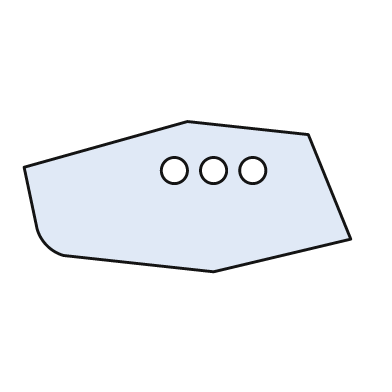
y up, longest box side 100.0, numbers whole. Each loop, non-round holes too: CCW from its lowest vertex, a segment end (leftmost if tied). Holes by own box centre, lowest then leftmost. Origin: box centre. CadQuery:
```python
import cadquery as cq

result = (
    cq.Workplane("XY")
    .moveTo(8.0, -23.0)
    .lineTo(50.0, -13.0)
    .lineTo(37.0, 19.0)
    .lineTo(0.0, 23.0)
    .lineTo(-50.0, 9.0)
    .lineTo(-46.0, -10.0)
    .threePointArc((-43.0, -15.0), (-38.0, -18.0))
    .close()
    .moveTo(-4.0, 8.0)
    .circle(4.0)
    .moveTo(8.0, 8.0)
    .circle(4.0)
    .moveTo(20.0, 8.0)
    .circle(4.0)
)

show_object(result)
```